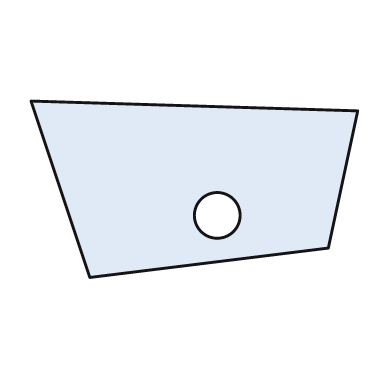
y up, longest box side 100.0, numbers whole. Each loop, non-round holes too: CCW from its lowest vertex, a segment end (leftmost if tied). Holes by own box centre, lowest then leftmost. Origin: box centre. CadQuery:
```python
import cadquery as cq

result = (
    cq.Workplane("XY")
    .moveTo(-32.0, -27.0)
    .lineTo(41.0, -18.0)
    .lineTo(50.0, 24.0)
    .lineTo(-50.0, 27.0)
    .close()
    .moveTo(7.0, -8.0)
    .circle(7.0)
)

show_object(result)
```